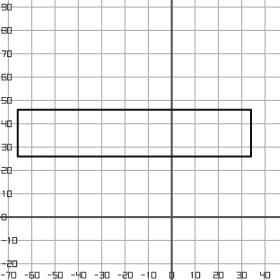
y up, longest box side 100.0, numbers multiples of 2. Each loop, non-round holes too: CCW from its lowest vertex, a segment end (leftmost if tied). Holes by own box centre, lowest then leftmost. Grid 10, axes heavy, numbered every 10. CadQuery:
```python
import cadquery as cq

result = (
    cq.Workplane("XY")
    .moveTo(-66.0, 26.0)
    .lineTo(34.0, 26.0)
    .lineTo(34.0, 46.0)
    .lineTo(-66.0, 46.0)
    .close()
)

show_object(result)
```